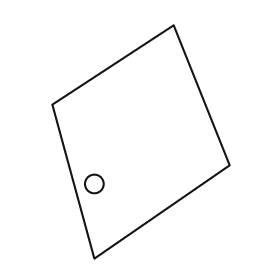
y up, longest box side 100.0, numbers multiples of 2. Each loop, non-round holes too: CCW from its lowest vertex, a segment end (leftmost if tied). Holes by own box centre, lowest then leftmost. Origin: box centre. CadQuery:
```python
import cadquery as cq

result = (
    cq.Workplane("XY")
    .moveTo(-20.0, -50.0)
    .lineTo(38.0, -10.0)
    .lineTo(14.0, 50.0)
    .lineTo(-38.0, 16.0)
    .close()
    .moveTo(-20.0, -18.0)
    .circle(4.0)
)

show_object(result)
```